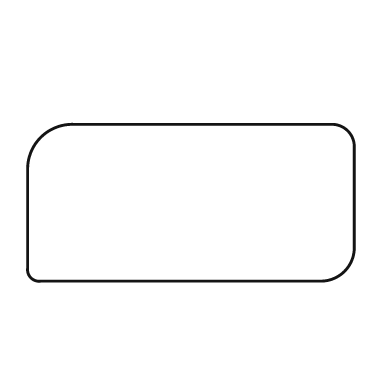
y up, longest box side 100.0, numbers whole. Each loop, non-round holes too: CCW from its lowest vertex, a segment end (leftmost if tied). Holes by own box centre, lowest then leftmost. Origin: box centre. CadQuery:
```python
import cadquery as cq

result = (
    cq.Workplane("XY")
    .moveTo(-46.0, -24.0)
    .lineTo(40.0, -24.0)
    .threePointArc((47.0, -21.0), (50.0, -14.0))
    .lineTo(50.0, 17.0)
    .threePointArc((48.0, 22.0), (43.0, 24.0))
    .lineTo(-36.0, 24.0)
    .threePointArc((-46.0, 20.0), (-50.0, 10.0))
    .lineTo(-50.0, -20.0)
    .threePointArc((-49.0, -23.0), (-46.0, -24.0))
    .close()
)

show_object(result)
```